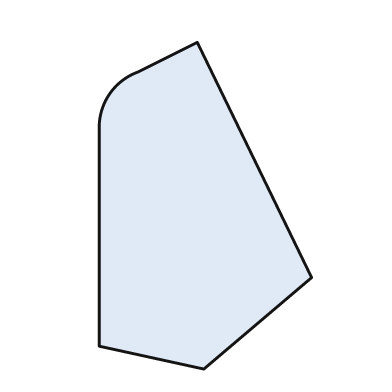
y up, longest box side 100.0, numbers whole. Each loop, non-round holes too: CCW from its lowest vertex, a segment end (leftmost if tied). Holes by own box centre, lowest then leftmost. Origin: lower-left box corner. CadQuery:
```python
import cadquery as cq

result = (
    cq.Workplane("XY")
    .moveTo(32.0, 0.0)
    .lineTo(65.0, 28.0)
    .lineTo(30.0, 100.0)
    .lineTo(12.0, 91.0)
    .threePointArc((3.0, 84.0), (0.0, 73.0))
    .lineTo(0.0, 7.0)
    .close()
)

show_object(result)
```